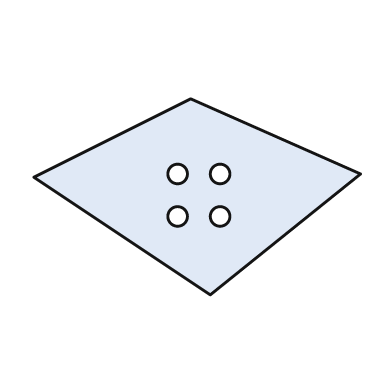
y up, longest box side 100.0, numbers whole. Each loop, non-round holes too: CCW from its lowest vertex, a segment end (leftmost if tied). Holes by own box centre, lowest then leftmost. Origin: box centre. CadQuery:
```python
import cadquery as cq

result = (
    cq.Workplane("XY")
    .moveTo(4.0, -30.0)
    .lineTo(50.0, 7.0)
    .lineTo(-2.0, 30.0)
    .lineTo(-50.0, 6.0)
    .close()
    .moveTo(-6.0, -6.0)
    .circle(3.0)
    .moveTo(7.0, -6.0)
    .circle(3.0)
    .moveTo(-6.0, 7.0)
    .circle(3.0)
    .moveTo(7.0, 7.0)
    .circle(3.0)
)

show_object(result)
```